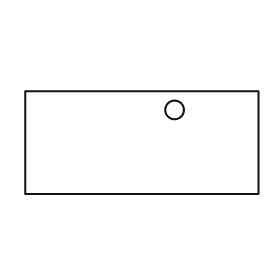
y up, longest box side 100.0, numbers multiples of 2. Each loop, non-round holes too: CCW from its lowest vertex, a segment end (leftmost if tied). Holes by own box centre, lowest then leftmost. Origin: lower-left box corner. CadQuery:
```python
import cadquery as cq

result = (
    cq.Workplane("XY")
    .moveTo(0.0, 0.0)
    .lineTo(100.0, 0.0)
    .lineTo(100.0, 44.0)
    .lineTo(0.0, 44.0)
    .close()
    .moveTo(64.0, 36.0)
    .circle(4.0)
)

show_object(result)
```